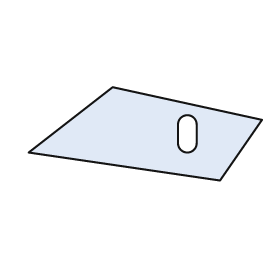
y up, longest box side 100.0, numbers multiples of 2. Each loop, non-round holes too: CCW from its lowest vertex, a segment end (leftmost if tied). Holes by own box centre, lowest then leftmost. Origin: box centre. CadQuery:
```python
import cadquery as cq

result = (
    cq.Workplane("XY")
    .moveTo(32.0, -20.0)
    .lineTo(50.0, 6.0)
    .lineTo(-14.0, 20.0)
    .lineTo(-50.0, -8.0)
    .close()
    .moveTo(14.0, -4.0)
    .threePointArc((18.0, -8.0), (22.0, -4.0))
    .lineTo(22.0, 4.0)
    .threePointArc((18.0, 8.0), (14.0, 4.0))
    .close()
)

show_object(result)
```